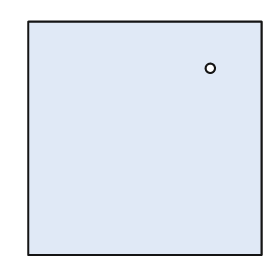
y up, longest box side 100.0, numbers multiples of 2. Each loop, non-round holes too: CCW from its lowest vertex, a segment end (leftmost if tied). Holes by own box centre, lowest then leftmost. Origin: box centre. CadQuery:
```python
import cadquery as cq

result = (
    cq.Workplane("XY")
    .moveTo(-50.0, -50.0)
    .lineTo(50.0, -50.0)
    .lineTo(50.0, 50.0)
    .lineTo(-50.0, 50.0)
    .close()
    .moveTo(28.0, 30.0)
    .circle(2.0)
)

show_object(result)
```